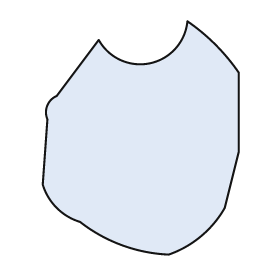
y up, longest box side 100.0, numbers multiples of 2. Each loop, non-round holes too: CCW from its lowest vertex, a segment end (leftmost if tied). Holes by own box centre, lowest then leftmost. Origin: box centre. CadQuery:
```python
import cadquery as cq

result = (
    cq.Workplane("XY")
    .moveTo(12.0, -50.0)
    .threePointArc((26.0, -42.0), (36.0, -30.0))
    .lineTo(42.0, -6.0)
    .lineTo(42.0, 28.0)
    .threePointArc((32.0, 40.0), (20.0, 50.0))
    .threePointArc((4.0, 32.0), (-18.0, 42.0))
    .lineTo(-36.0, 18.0)
    .threePointArc((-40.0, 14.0), (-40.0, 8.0))
    .lineTo(-42.0, -20.0)
    .threePointArc((-36.0, -30.0), (-26.0, -36.0))
    .threePointArc((-8.0, -46.0), (12.0, -50.0))
    .close()
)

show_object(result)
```